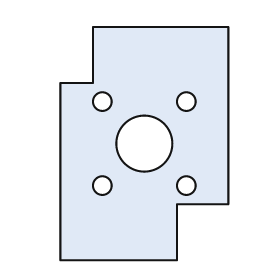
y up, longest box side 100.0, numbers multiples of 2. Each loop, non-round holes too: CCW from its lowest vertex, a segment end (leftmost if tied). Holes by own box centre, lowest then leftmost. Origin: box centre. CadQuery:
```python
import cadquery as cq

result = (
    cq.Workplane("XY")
    .moveTo(-36.0, -50.0)
    .lineTo(14.0, -50.0)
    .lineTo(14.0, -26.0)
    .lineTo(36.0, -26.0)
    .lineTo(36.0, 50.0)
    .lineTo(-22.0, 50.0)
    .lineTo(-22.0, 26.0)
    .lineTo(-36.0, 26.0)
    .close()
    .moveTo(-18.0, -18.0)
    .circle(4.0)
    .moveTo(18.0, -18.0)
    .circle(4.0)
    .moveTo(0.0, 0.0)
    .circle(12.0)
    .moveTo(-18.0, 18.0)
    .circle(4.0)
    .moveTo(18.0, 18.0)
    .circle(4.0)
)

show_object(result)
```